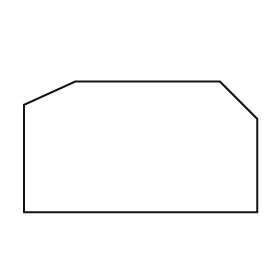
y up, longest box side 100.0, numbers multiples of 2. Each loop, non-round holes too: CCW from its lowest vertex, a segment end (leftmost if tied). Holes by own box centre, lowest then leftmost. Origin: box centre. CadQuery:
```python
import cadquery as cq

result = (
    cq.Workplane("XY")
    .moveTo(-50.0, -28.0)
    .lineTo(50.0, -28.0)
    .lineTo(50.0, 12.0)
    .lineTo(34.0, 28.0)
    .lineTo(-28.0, 28.0)
    .lineTo(-50.0, 18.0)
    .close()
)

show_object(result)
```